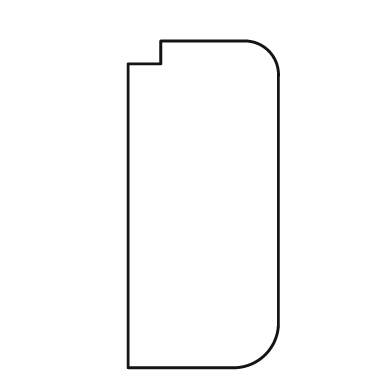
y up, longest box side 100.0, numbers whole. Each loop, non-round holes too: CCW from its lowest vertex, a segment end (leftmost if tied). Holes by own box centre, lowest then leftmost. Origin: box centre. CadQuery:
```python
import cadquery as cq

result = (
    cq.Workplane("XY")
    .moveTo(-23.0, -50.0)
    .lineTo(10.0, -50.0)
    .threePointArc((19.0, -46.0), (23.0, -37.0))
    .lineTo(23.0, 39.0)
    .threePointArc((20.0, 47.0), (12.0, 50.0))
    .lineTo(-13.0, 50.0)
    .lineTo(-13.0, 43.0)
    .lineTo(-23.0, 43.0)
    .close()
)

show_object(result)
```